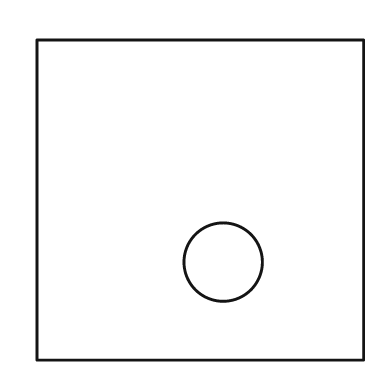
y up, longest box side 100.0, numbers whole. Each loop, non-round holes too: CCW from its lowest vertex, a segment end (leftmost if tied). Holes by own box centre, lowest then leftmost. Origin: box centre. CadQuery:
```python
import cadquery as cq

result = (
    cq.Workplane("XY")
    .moveTo(-50.0, -49.0)
    .lineTo(50.0, -49.0)
    .lineTo(50.0, 49.0)
    .lineTo(-50.0, 49.0)
    .close()
    .moveTo(7.0, -19.0)
    .circle(12.0)
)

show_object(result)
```